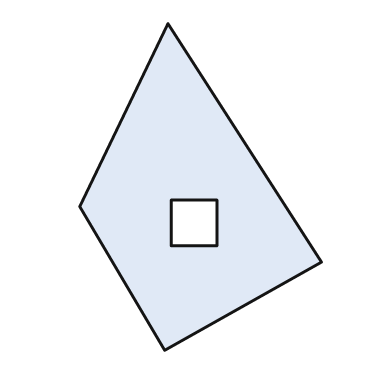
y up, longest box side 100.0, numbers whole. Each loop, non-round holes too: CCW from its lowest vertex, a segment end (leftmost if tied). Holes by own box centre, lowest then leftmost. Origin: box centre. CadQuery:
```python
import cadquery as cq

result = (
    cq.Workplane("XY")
    .moveTo(-11.0, -50.0)
    .lineTo(37.0, -23.0)
    .lineTo(-10.0, 50.0)
    .lineTo(-37.0, -6.0)
    .close()
    .moveTo(-9.0, -18.0)
    .lineTo(5.0, -18.0)
    .lineTo(5.0, -4.0)
    .lineTo(-9.0, -4.0)
    .close()
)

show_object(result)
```